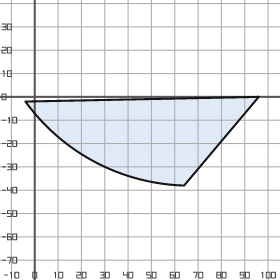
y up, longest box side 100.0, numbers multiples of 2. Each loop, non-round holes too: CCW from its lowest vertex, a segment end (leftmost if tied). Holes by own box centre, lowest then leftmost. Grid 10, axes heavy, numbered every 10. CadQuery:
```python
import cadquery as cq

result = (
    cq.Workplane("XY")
    .moveTo(64.0, -38.0)
    .lineTo(96.0, 0.0)
    .lineTo(-4.0, -2.0)
    .threePointArc((26.0, -28.0), (64.0, -38.0))
    .close()
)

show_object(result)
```